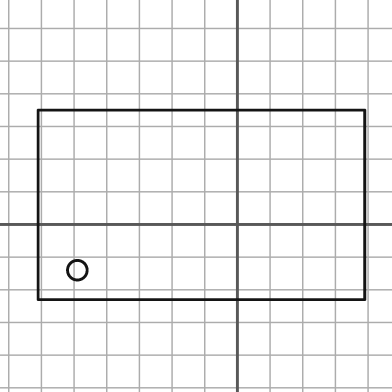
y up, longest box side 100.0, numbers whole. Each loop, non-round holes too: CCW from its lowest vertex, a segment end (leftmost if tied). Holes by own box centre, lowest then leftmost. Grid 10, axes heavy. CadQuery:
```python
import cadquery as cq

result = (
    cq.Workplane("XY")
    .moveTo(-61.0, -23.0)
    .lineTo(39.0, -23.0)
    .lineTo(39.0, 35.0)
    .lineTo(-61.0, 35.0)
    .close()
    .moveTo(-49.0, -14.0)
    .circle(3.0)
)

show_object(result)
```